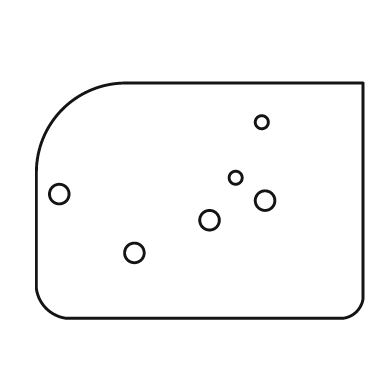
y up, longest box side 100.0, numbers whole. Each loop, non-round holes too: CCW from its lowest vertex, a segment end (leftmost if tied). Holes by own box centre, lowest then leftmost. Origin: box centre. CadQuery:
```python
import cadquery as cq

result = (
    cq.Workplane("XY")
    .moveTo(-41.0, -36.0)
    .lineTo(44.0, -36.0)
    .threePointArc((48.0, -34.0), (50.0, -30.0))
    .lineTo(50.0, 36.0)
    .lineTo(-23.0, 36.0)
    .threePointArc((-42.0, 28.0), (-50.0, 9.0))
    .lineTo(-50.0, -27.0)
    .threePointArc((-47.0, -33.0), (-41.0, -36.0))
    .close()
    .moveTo(-20.0, -16.0)
    .circle(3.0)
    .moveTo(3.0, -6.0)
    .circle(3.0)
    .moveTo(20.0, 0.0)
    .circle(3.0)
    .moveTo(-43.0, 2.0)
    .circle(3.0)
    .moveTo(11.0, 7.0)
    .circle(2.0)
    .moveTo(19.0, 24.0)
    .circle(2.0)
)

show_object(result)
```